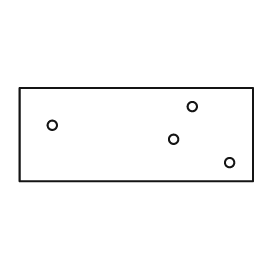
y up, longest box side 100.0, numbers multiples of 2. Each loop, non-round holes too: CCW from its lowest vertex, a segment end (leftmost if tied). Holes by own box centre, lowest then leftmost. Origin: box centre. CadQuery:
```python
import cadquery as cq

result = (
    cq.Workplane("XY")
    .moveTo(-50.0, -20.0)
    .lineTo(50.0, -20.0)
    .lineTo(50.0, 20.0)
    .lineTo(-50.0, 20.0)
    .close()
    .moveTo(40.0, -12.0)
    .circle(2.0)
    .moveTo(16.0, -2.0)
    .circle(2.0)
    .moveTo(-36.0, 4.0)
    .circle(2.0)
    .moveTo(24.0, 12.0)
    .circle(2.0)
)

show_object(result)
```